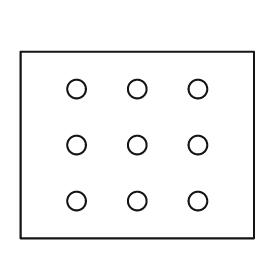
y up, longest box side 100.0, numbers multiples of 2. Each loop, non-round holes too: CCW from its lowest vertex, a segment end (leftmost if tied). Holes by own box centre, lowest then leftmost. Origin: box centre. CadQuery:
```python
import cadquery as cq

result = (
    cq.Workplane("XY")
    .moveTo(-50.0, -40.0)
    .lineTo(50.0, -40.0)
    .lineTo(50.0, 40.0)
    .lineTo(-50.0, 40.0)
    .close()
    .moveTo(-26.0, -24.0)
    .circle(4.0)
    .moveTo(0.0, -24.0)
    .circle(4.0)
    .moveTo(26.0, -24.0)
    .circle(4.0)
    .moveTo(-26.0, 0.0)
    .circle(4.0)
    .moveTo(0.0, 0.0)
    .circle(4.0)
    .moveTo(26.0, 0.0)
    .circle(4.0)
    .moveTo(-26.0, 24.0)
    .circle(4.0)
    .moveTo(0.0, 24.0)
    .circle(4.0)
    .moveTo(26.0, 24.0)
    .circle(4.0)
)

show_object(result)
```